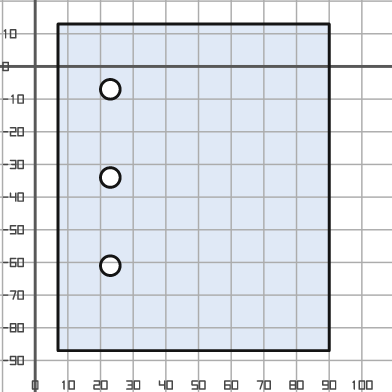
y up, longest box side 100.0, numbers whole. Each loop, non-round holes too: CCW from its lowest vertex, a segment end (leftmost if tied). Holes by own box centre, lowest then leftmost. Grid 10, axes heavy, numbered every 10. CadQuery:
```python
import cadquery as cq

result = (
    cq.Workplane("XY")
    .moveTo(7.0, -87.0)
    .lineTo(90.0, -87.0)
    .lineTo(90.0, 13.0)
    .lineTo(7.0, 13.0)
    .close()
    .moveTo(23.0, -61.0)
    .circle(3.0)
    .moveTo(23.0, -34.0)
    .circle(3.0)
    .moveTo(23.0, -7.0)
    .circle(3.0)
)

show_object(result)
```